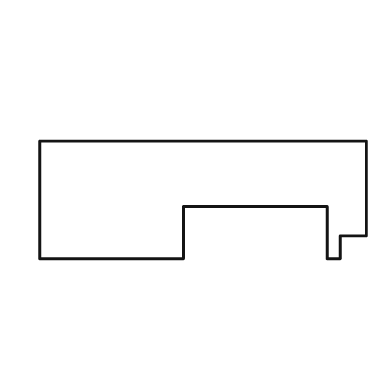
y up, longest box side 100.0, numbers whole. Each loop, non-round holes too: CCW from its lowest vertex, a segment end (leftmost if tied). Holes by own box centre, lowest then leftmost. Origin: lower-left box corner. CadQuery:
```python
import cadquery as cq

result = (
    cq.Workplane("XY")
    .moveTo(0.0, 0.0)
    .lineTo(44.0, 0.0)
    .lineTo(44.0, 16.0)
    .lineTo(88.0, 16.0)
    .lineTo(88.0, 0.0)
    .lineTo(92.0, 0.0)
    .lineTo(92.0, 7.0)
    .lineTo(100.0, 7.0)
    .lineTo(100.0, 36.0)
    .lineTo(0.0, 36.0)
    .close()
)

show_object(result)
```